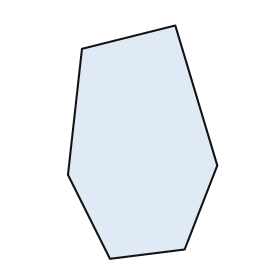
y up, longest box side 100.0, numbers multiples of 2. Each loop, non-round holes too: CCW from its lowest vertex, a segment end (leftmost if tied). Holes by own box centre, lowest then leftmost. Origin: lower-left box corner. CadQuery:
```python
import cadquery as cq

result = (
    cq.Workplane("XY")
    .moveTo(18.0, 0.0)
    .lineTo(50.0, 4.0)
    .lineTo(64.0, 40.0)
    .lineTo(46.0, 100.0)
    .lineTo(6.0, 90.0)
    .lineTo(0.0, 36.0)
    .close()
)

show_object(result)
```